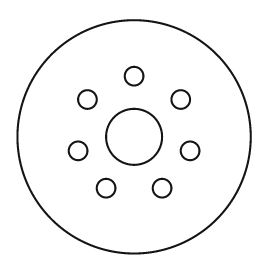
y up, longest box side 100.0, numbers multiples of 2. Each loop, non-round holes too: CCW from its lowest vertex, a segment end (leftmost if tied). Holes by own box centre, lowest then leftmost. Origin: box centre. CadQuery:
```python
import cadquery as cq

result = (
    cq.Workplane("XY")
    .moveTo(0.0, 0.0)
    .circle(50.0)
    .moveTo(-12.0, -22.0)
    .circle(4.0)
    .moveTo(12.0, -22.0)
    .circle(4.0)
    .moveTo(-24.0, -6.0)
    .circle(4.0)
    .moveTo(24.0, -6.0)
    .circle(4.0)
    .moveTo(0.0, 0.0)
    .circle(12.0)
    .moveTo(-20.0, 16.0)
    .circle(4.0)
    .moveTo(20.0, 16.0)
    .circle(4.0)
    .moveTo(0.0, 26.0)
    .circle(4.0)
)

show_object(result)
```